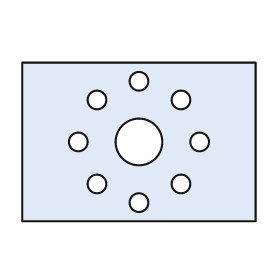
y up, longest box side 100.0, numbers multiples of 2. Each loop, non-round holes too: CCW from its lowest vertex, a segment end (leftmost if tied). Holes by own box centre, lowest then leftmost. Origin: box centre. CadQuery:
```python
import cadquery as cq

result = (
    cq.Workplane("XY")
    .moveTo(-50.0, -34.0)
    .lineTo(50.0, -34.0)
    .lineTo(50.0, 34.0)
    .lineTo(-50.0, 34.0)
    .close()
    .moveTo(0.0, -26.0)
    .circle(4.0)
    .moveTo(-18.0, -18.0)
    .circle(4.0)
    .moveTo(18.0, -18.0)
    .circle(4.0)
    .moveTo(-26.0, 0.0)
    .circle(4.0)
    .moveTo(0.0, 0.0)
    .circle(10.0)
    .moveTo(26.0, 0.0)
    .circle(4.0)
    .moveTo(-18.0, 18.0)
    .circle(4.0)
    .moveTo(18.0, 18.0)
    .circle(4.0)
    .moveTo(0.0, 26.0)
    .circle(4.0)
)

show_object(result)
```